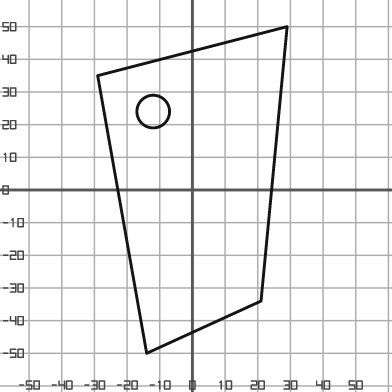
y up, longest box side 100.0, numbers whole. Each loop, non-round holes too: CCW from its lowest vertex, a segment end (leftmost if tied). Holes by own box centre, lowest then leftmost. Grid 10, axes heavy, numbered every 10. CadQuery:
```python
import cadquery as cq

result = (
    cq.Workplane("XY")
    .moveTo(-14.0, -50.0)
    .lineTo(21.0, -34.0)
    .lineTo(29.0, 50.0)
    .lineTo(-29.0, 35.0)
    .close()
    .moveTo(-12.0, 24.0)
    .circle(5.0)
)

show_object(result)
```